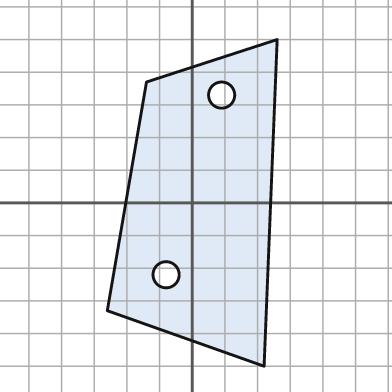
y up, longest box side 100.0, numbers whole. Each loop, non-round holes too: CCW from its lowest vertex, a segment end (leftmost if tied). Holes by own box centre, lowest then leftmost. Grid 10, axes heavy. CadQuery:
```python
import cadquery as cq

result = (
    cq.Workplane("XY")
    .moveTo(22.0, -50.0)
    .lineTo(26.0, 50.0)
    .lineTo(-14.0, 37.0)
    .lineTo(-26.0, -33.0)
    .close()
    .moveTo(-8.0, -22.0)
    .circle(4.0)
    .moveTo(9.0, 33.0)
    .circle(4.0)
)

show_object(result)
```